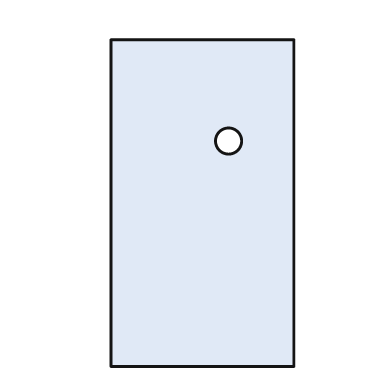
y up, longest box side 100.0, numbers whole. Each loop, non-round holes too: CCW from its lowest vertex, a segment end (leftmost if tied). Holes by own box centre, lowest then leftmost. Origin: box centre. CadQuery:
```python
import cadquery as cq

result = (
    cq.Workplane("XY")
    .moveTo(-28.0, -50.0)
    .lineTo(28.0, -50.0)
    .lineTo(28.0, 50.0)
    .lineTo(-28.0, 50.0)
    .close()
    .moveTo(8.0, 19.0)
    .circle(4.0)
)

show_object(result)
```